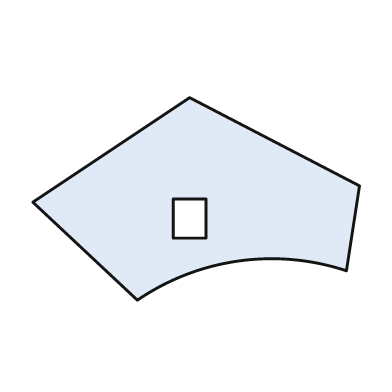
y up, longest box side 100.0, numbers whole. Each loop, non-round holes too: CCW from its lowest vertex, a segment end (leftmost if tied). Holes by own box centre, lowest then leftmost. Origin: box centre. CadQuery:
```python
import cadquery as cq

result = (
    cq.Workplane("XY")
    .moveTo(-18.0, -31.0)
    .threePointArc((13.0, -19.0), (46.0, -22.0))
    .lineTo(50.0, 4.0)
    .lineTo(-2.0, 31.0)
    .lineTo(-50.0, -1.0)
    .close()
    .moveTo(-7.0, -12.0)
    .lineTo(3.0, -12.0)
    .lineTo(3.0, 0.0)
    .lineTo(-7.0, 0.0)
    .close()
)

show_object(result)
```